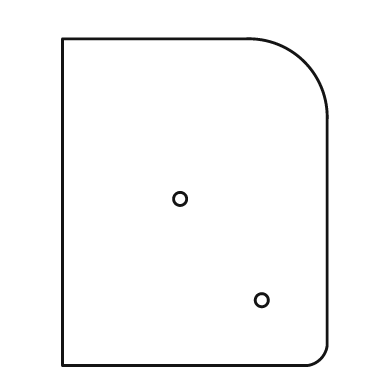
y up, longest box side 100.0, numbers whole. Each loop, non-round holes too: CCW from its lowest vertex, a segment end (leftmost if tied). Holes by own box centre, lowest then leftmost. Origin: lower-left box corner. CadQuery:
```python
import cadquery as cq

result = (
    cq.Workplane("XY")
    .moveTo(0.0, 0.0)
    .lineTo(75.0, 0.0)
    .threePointArc((79.0, 2.0), (81.0, 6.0))
    .lineTo(81.0, 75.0)
    .threePointArc((74.0, 93.0), (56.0, 100.0))
    .lineTo(0.0, 100.0)
    .close()
    .moveTo(61.0, 20.0)
    .circle(2.0)
    .moveTo(36.0, 51.0)
    .circle(2.0)
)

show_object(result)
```